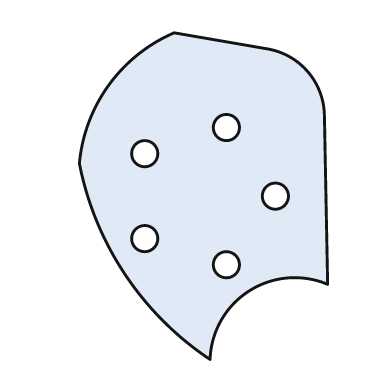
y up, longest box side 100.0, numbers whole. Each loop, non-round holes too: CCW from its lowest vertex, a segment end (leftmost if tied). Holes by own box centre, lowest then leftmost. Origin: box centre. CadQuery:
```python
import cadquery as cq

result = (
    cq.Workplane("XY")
    .moveTo(2.0, -50.0)
    .threePointArc((14.0, -29.0), (38.0, -27.0))
    .lineTo(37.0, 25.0)
    .threePointArc((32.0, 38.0), (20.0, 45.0))
    .lineTo(-9.0, 50.0)
    .threePointArc((-29.0, 34.0), (-38.0, 10.0))
    .threePointArc((-24.0, -24.0), (2.0, -50.0))
    .close()
    .moveTo(7.0, -21.0)
    .circle(4.0)
    .moveTo(-18.0, -13.0)
    .circle(4.0)
    .moveTo(22.0, 0.0)
    .circle(4.0)
    .moveTo(-18.0, 13.0)
    .circle(4.0)
    .moveTo(7.0, 21.0)
    .circle(4.0)
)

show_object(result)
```